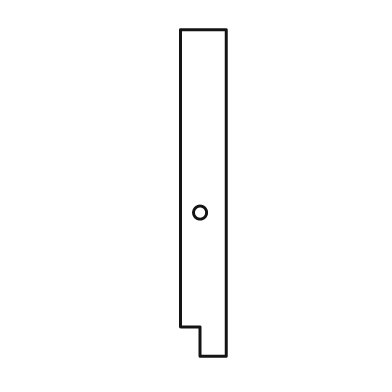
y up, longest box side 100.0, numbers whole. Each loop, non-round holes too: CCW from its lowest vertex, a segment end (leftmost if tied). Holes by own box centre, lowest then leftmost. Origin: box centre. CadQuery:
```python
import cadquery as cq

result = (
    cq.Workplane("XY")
    .moveTo(-1.0, -50.0)
    .lineTo(7.0, -50.0)
    .lineTo(7.0, 50.0)
    .lineTo(-7.0, 50.0)
    .lineTo(-7.0, -41.0)
    .lineTo(-1.0, -41.0)
    .close()
    .moveTo(-1.0, -6.0)
    .circle(2.0)
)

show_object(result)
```